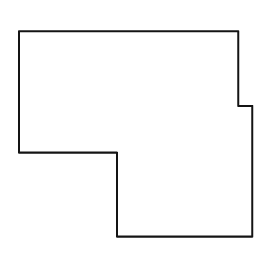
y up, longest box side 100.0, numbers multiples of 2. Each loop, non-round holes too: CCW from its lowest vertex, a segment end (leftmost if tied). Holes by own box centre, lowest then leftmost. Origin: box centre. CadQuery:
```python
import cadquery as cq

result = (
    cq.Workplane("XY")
    .moveTo(-8.0, -44.0)
    .lineTo(50.0, -44.0)
    .lineTo(50.0, 12.0)
    .lineTo(44.0, 12.0)
    .lineTo(44.0, 44.0)
    .lineTo(-50.0, 44.0)
    .lineTo(-50.0, -8.0)
    .lineTo(-8.0, -8.0)
    .close()
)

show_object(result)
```